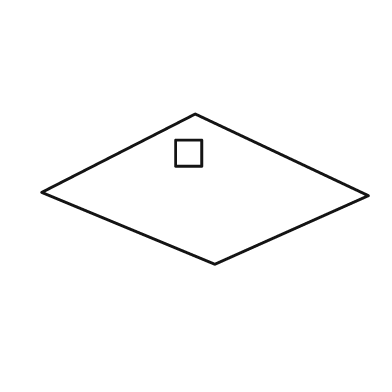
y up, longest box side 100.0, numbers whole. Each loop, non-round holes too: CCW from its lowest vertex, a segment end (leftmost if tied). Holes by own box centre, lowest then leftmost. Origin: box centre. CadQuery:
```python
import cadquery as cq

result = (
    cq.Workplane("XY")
    .moveTo(3.0, -23.0)
    .lineTo(50.0, -2.0)
    .lineTo(-3.0, 23.0)
    .lineTo(-50.0, -1.0)
    .close()
    .moveTo(-9.0, 7.0)
    .lineTo(-1.0, 7.0)
    .lineTo(-1.0, 15.0)
    .lineTo(-9.0, 15.0)
    .close()
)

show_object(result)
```